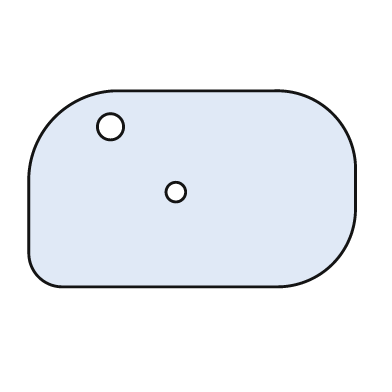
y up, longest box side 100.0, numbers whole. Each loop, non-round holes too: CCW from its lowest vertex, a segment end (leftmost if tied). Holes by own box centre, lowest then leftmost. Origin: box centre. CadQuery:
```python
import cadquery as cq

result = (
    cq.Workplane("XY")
    .moveTo(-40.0, -30.0)
    .lineTo(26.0, -30.0)
    .threePointArc((43.0, -23.0), (50.0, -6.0))
    .lineTo(50.0, 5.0)
    .threePointArc((43.0, 23.0), (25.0, 30.0))
    .lineTo(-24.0, 30.0)
    .threePointArc((-42.0, 22.0), (-50.0, 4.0))
    .lineTo(-50.0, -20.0)
    .threePointArc((-47.0, -27.0), (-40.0, -30.0))
    .close()
    .moveTo(-5.0, -1.0)
    .circle(3.0)
    .moveTo(-25.0, 19.0)
    .circle(4.0)
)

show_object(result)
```